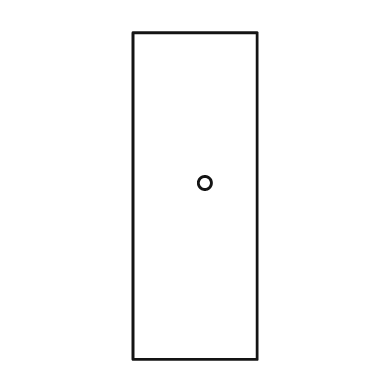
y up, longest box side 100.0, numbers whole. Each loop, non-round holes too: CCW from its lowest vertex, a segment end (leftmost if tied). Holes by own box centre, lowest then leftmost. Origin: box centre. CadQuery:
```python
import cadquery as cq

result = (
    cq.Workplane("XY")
    .moveTo(-19.0, -50.0)
    .lineTo(19.0, -50.0)
    .lineTo(19.0, 50.0)
    .lineTo(-19.0, 50.0)
    .close()
    .moveTo(3.0, 4.0)
    .circle(2.0)
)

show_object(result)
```